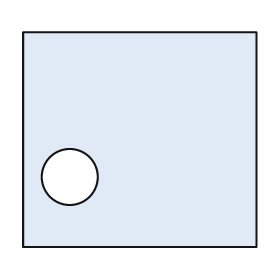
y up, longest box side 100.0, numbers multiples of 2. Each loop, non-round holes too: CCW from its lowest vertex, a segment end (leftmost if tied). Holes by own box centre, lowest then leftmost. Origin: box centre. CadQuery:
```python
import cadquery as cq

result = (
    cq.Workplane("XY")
    .moveTo(-50.0, -46.0)
    .lineTo(50.0, -46.0)
    .lineTo(50.0, 46.0)
    .lineTo(-50.0, 46.0)
    .close()
    .moveTo(-30.0, -16.0)
    .circle(12.0)
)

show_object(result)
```